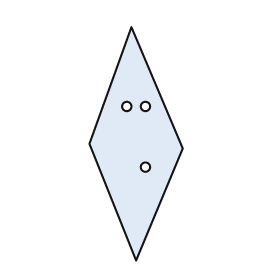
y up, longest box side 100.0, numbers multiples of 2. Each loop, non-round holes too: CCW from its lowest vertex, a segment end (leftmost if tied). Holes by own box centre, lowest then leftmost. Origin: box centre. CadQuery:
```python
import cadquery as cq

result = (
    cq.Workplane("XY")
    .moveTo(0.0, -50.0)
    .lineTo(20.0, -2.0)
    .lineTo(-2.0, 50.0)
    .lineTo(-20.0, 0.0)
    .close()
    .moveTo(4.0, -10.0)
    .circle(2.0)
    .moveTo(-4.0, 16.0)
    .circle(2.0)
    .moveTo(4.0, 16.0)
    .circle(2.0)
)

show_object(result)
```